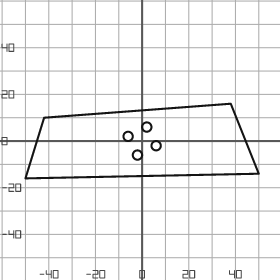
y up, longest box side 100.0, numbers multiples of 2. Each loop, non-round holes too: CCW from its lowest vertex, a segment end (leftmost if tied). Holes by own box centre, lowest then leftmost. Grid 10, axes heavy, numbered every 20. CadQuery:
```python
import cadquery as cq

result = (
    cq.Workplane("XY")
    .moveTo(-50.0, -16.0)
    .lineTo(50.0, -14.0)
    .lineTo(38.0, 16.0)
    .lineTo(-42.0, 10.0)
    .close()
    .moveTo(-2.0, -6.0)
    .circle(2.0)
    .moveTo(6.0, -2.0)
    .circle(2.0)
    .moveTo(-6.0, 2.0)
    .circle(2.0)
    .moveTo(2.0, 6.0)
    .circle(2.0)
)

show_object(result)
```